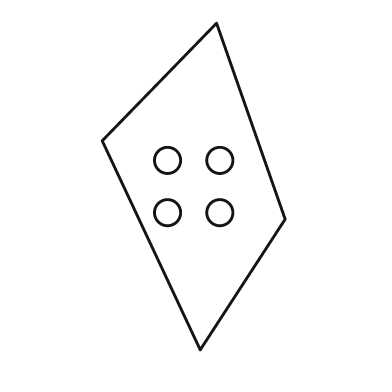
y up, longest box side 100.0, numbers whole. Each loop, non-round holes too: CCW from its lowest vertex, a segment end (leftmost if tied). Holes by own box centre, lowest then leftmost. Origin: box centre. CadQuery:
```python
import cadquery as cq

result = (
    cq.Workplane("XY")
    .moveTo(2.0, -50.0)
    .lineTo(28.0, -10.0)
    .lineTo(7.0, 50.0)
    .lineTo(-28.0, 14.0)
    .close()
    .moveTo(-8.0, -8.0)
    .circle(4.0)
    .moveTo(8.0, -8.0)
    .circle(4.0)
    .moveTo(-8.0, 8.0)
    .circle(4.0)
    .moveTo(8.0, 8.0)
    .circle(4.0)
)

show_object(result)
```